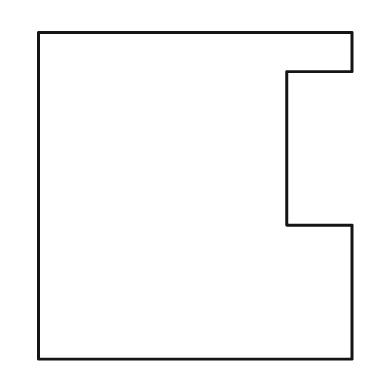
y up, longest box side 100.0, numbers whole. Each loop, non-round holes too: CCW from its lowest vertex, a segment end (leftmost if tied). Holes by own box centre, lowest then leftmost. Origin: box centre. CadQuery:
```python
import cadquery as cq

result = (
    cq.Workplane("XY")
    .moveTo(-48.0, -50.0)
    .lineTo(48.0, -50.0)
    .lineTo(48.0, -9.0)
    .lineTo(28.0, -9.0)
    .lineTo(28.0, 38.0)
    .lineTo(48.0, 38.0)
    .lineTo(48.0, 50.0)
    .lineTo(-48.0, 50.0)
    .close()
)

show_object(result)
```